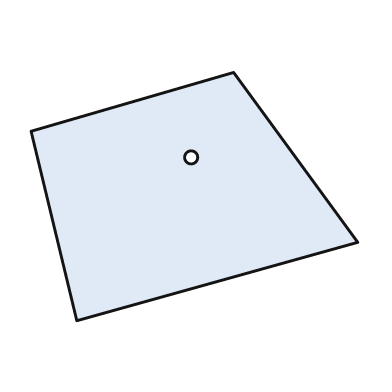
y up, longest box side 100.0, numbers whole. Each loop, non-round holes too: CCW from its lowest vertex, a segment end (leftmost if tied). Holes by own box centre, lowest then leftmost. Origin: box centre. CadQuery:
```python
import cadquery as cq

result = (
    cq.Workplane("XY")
    .moveTo(-36.0, -38.0)
    .lineTo(50.0, -14.0)
    .lineTo(12.0, 38.0)
    .lineTo(-50.0, 20.0)
    .close()
    .moveTo(-1.0, 12.0)
    .circle(2.0)
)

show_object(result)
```